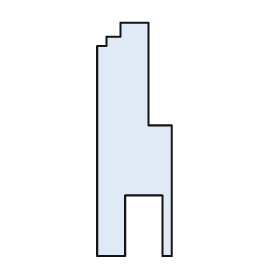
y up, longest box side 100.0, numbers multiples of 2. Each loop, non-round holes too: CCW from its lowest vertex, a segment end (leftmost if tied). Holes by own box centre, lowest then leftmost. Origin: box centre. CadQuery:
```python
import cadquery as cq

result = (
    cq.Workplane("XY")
    .moveTo(-16.0, -50.0)
    .lineTo(-4.0, -50.0)
    .lineTo(-4.0, -24.0)
    .lineTo(12.0, -24.0)
    .lineTo(12.0, -50.0)
    .lineTo(16.0, -50.0)
    .lineTo(16.0, 6.0)
    .lineTo(6.0, 6.0)
    .lineTo(6.0, 50.0)
    .lineTo(-6.0, 50.0)
    .lineTo(-6.0, 44.0)
    .lineTo(-12.0, 44.0)
    .lineTo(-12.0, 40.0)
    .lineTo(-16.0, 40.0)
    .close()
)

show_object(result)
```